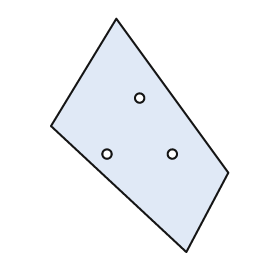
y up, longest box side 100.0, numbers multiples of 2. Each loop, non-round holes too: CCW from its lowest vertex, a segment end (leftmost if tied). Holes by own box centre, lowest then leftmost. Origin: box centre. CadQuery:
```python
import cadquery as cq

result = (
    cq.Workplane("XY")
    .moveTo(20.0, -50.0)
    .lineTo(38.0, -16.0)
    .lineTo(-10.0, 50.0)
    .lineTo(-38.0, 4.0)
    .close()
    .moveTo(-14.0, -8.0)
    .circle(2.0)
    .moveTo(14.0, -8.0)
    .circle(2.0)
    .moveTo(0.0, 16.0)
    .circle(2.0)
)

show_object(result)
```